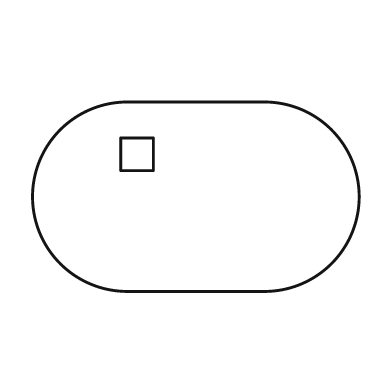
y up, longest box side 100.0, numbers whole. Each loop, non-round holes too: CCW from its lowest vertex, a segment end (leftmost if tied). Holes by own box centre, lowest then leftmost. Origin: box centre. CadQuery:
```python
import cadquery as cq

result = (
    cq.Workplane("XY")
    .moveTo(-21.0, -29.0)
    .lineTo(21.0, -29.0)
    .threePointArc((50.0, 0.0), (21.0, 29.0))
    .lineTo(-21.0, 29.0)
    .threePointArc((-50.0, 0.0), (-21.0, -29.0))
    .close()
    .moveTo(-23.0, 8.0)
    .lineTo(-13.0, 8.0)
    .lineTo(-13.0, 18.0)
    .lineTo(-23.0, 18.0)
    .close()
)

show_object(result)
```